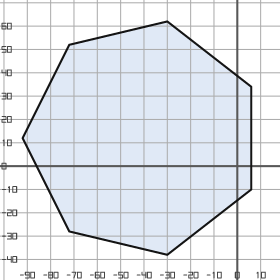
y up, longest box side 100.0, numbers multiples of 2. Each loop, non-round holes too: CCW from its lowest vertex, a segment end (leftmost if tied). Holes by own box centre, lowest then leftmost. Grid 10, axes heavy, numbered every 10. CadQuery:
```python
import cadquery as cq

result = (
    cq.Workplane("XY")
    .moveTo(-30.0, -38.0)
    .lineTo(6.0, -10.0)
    .lineTo(6.0, 34.0)
    .lineTo(-30.0, 62.0)
    .lineTo(-72.0, 52.0)
    .lineTo(-92.0, 12.0)
    .lineTo(-72.0, -28.0)
    .close()
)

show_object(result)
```